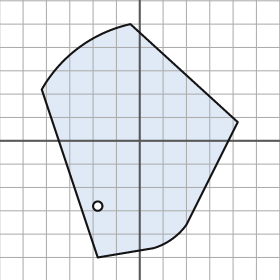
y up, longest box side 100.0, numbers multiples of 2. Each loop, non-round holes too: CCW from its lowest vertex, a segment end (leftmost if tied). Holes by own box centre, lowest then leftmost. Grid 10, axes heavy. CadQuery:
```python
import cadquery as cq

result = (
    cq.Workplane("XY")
    .moveTo(-18.0, -50.0)
    .lineTo(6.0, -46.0)
    .threePointArc((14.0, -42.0), (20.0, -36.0))
    .lineTo(42.0, 8.0)
    .lineTo(-4.0, 50.0)
    .threePointArc((-26.0, 40.0), (-42.0, 22.0))
    .close()
    .moveTo(-18.0, -28.0)
    .circle(2.0)
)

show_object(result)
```